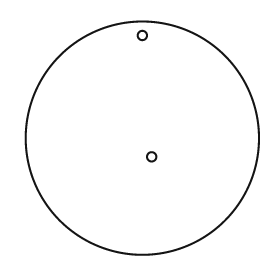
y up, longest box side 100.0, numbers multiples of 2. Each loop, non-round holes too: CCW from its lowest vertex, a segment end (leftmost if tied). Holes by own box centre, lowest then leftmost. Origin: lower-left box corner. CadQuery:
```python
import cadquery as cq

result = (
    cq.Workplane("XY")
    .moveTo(50.0, 50.0)
    .circle(50.0)
    .moveTo(54.0, 42.0)
    .circle(2.0)
    .moveTo(50.0, 94.0)
    .circle(2.0)
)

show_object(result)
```